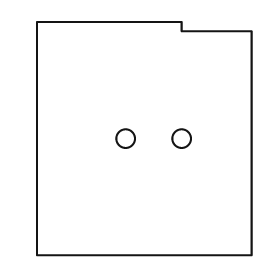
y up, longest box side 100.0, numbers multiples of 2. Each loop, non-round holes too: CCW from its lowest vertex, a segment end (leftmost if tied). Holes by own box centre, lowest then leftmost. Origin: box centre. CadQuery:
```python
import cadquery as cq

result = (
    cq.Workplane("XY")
    .moveTo(-46.0, -50.0)
    .lineTo(46.0, -50.0)
    .lineTo(46.0, 46.0)
    .lineTo(16.0, 46.0)
    .lineTo(16.0, 50.0)
    .lineTo(-46.0, 50.0)
    .close()
    .moveTo(-8.0, 0.0)
    .circle(4.0)
    .moveTo(16.0, 0.0)
    .circle(4.0)
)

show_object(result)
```